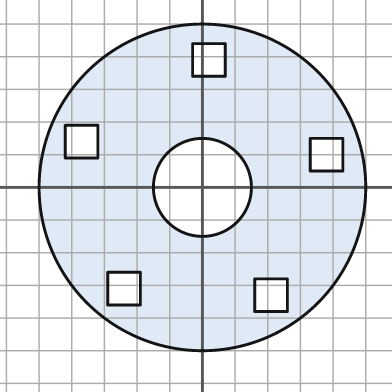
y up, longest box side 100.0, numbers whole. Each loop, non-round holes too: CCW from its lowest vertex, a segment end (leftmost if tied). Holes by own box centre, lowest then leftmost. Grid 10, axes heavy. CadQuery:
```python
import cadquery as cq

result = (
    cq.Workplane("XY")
    .moveTo(0.0, 0.0)
    .circle(50.0)
    .moveTo(16.0, -38.0)
    .lineTo(26.0, -38.0)
    .lineTo(26.0, -28.0)
    .lineTo(16.0, -28.0)
    .close()
    .moveTo(-29.0, -36.0)
    .lineTo(-19.0, -36.0)
    .lineTo(-19.0, -26.0)
    .lineTo(-29.0, -26.0)
    .close()
    .moveTo(0.0, 0.0)
    .circle(15.0)
    .moveTo(33.0, 5.0)
    .lineTo(43.0, 5.0)
    .lineTo(43.0, 15.0)
    .lineTo(33.0, 15.0)
    .close()
    .moveTo(-42.0, 9.0)
    .lineTo(-32.0, 9.0)
    .lineTo(-32.0, 19.0)
    .lineTo(-42.0, 19.0)
    .close()
    .moveTo(-3.0, 34.0)
    .lineTo(7.0, 34.0)
    .lineTo(7.0, 44.0)
    .lineTo(-3.0, 44.0)
    .close()
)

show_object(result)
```